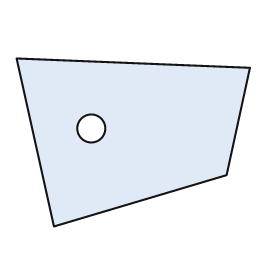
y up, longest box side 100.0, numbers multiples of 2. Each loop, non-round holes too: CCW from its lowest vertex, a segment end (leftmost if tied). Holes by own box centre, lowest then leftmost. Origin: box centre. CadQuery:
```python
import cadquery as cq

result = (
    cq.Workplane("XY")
    .moveTo(-34.0, -36.0)
    .lineTo(40.0, -14.0)
    .lineTo(50.0, 32.0)
    .lineTo(-50.0, 36.0)
    .close()
    .moveTo(-18.0, 6.0)
    .circle(6.0)
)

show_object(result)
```